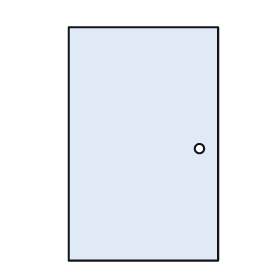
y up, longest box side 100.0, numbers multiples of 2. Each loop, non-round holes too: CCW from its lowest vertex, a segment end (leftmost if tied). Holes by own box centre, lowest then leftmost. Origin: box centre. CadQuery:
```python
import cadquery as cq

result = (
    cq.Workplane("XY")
    .moveTo(-32.0, -50.0)
    .lineTo(32.0, -50.0)
    .lineTo(32.0, 50.0)
    .lineTo(-32.0, 50.0)
    .close()
    .moveTo(24.0, -2.0)
    .circle(2.0)
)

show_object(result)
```